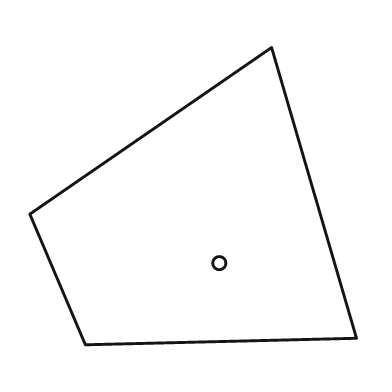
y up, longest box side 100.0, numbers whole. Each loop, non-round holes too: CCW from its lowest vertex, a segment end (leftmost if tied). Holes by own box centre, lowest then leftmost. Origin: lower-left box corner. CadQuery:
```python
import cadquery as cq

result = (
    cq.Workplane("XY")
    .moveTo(17.0, 0.0)
    .lineTo(100.0, 2.0)
    .lineTo(74.0, 91.0)
    .lineTo(0.0, 40.0)
    .close()
    .moveTo(58.0, 25.0)
    .circle(2.0)
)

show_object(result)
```